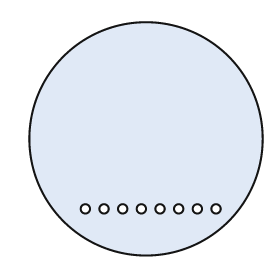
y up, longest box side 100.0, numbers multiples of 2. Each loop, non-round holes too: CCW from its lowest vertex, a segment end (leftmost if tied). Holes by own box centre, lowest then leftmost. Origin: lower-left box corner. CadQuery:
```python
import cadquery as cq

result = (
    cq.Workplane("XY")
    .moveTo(50.0, 50.0)
    .circle(50.0)
    .moveTo(24.0, 20.0)
    .circle(2.0)
    .moveTo(32.0, 20.0)
    .circle(2.0)
    .moveTo(40.0, 20.0)
    .circle(2.0)
    .moveTo(48.0, 20.0)
    .circle(2.0)
    .moveTo(56.0, 20.0)
    .circle(2.0)
    .moveTo(64.0, 20.0)
    .circle(2.0)
    .moveTo(72.0, 20.0)
    .circle(2.0)
    .moveTo(80.0, 20.0)
    .circle(2.0)
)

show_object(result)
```